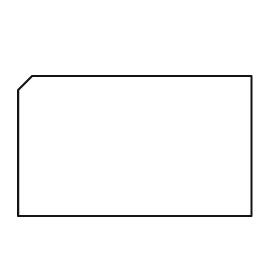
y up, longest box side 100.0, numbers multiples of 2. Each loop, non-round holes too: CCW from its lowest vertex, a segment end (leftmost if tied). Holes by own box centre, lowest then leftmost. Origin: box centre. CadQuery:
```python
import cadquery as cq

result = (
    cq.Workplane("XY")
    .moveTo(-50.0, -30.0)
    .lineTo(50.0, -30.0)
    .lineTo(50.0, 30.0)
    .lineTo(-44.0, 30.0)
    .lineTo(-50.0, 24.0)
    .close()
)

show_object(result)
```